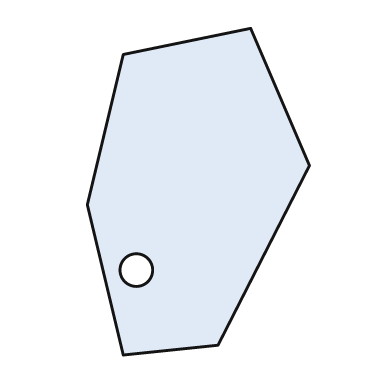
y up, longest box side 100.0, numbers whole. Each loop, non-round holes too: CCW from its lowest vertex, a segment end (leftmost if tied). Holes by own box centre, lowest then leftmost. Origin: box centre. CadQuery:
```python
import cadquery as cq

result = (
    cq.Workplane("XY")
    .moveTo(-23.0, -50.0)
    .lineTo(6.0, -47.0)
    .lineTo(34.0, 8.0)
    .lineTo(16.0, 50.0)
    .lineTo(-23.0, 42.0)
    .lineTo(-34.0, -4.0)
    .close()
    .moveTo(-19.0, -24.0)
    .circle(5.0)
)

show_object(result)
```